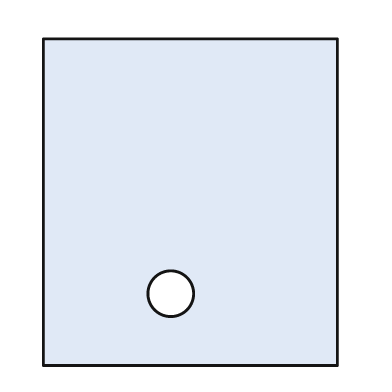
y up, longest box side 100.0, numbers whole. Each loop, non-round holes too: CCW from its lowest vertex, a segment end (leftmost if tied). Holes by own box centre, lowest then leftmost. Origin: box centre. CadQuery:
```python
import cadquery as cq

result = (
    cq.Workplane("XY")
    .moveTo(-45.0, -50.0)
    .lineTo(45.0, -50.0)
    .lineTo(45.0, 50.0)
    .lineTo(-45.0, 50.0)
    .close()
    .moveTo(-6.0, -28.0)
    .circle(7.0)
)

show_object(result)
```